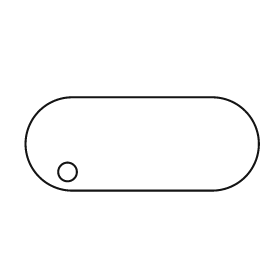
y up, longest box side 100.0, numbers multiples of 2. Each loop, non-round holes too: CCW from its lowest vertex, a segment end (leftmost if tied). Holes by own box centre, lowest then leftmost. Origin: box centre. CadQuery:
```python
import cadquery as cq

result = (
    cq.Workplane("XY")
    .moveTo(-30.0, -20.0)
    .lineTo(30.0, -20.0)
    .threePointArc((50.0, 0.0), (30.0, 20.0))
    .lineTo(-30.0, 20.0)
    .threePointArc((-50.0, 0.0), (-30.0, -20.0))
    .close()
    .moveTo(-32.0, -12.0)
    .circle(4.0)
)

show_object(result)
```